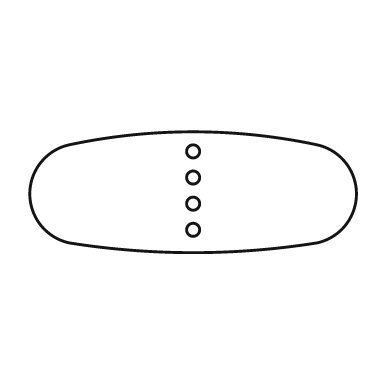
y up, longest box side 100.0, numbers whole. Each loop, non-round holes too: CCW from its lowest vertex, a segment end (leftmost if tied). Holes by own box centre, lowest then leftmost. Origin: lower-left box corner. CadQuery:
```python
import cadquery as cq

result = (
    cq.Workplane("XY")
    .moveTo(12.0, 3.0)
    .threePointArc((50.0, 0.0), (88.0, 3.0))
    .threePointArc((100.0, 18.0), (88.0, 33.0))
    .threePointArc((50.0, 37.0), (12.0, 33.0))
    .threePointArc((0.0, 18.0), (12.0, 3.0))
    .close()
    .moveTo(50.0, 7.0)
    .circle(2.0)
    .moveTo(50.0, 15.0)
    .circle(2.0)
    .moveTo(50.0, 23.0)
    .circle(2.0)
    .moveTo(50.0, 31.0)
    .circle(2.0)
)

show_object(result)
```